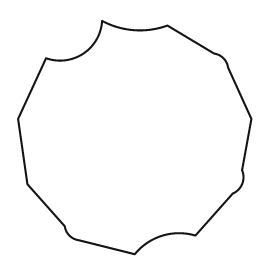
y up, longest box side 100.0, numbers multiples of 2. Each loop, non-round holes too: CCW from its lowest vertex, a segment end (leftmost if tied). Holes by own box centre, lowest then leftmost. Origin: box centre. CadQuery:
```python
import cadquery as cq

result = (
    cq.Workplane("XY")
    .moveTo(0.0, -50.0)
    .threePointArc((12.0, -42.0), (26.0, -42.0))
    .lineTo(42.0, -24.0)
    .threePointArc((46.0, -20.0), (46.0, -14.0))
    .lineTo(50.0, 8.0)
    .lineTo(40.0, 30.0)
    .threePointArc((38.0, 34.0), (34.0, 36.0))
    .lineTo(14.0, 48.0)
    .threePointArc((0.0, 46.0), (-14.0, 50.0))
    .threePointArc((-22.0, 36.0), (-38.0, 34.0))
    .lineTo(-50.0, 8.0)
    .lineTo(-46.0, -20.0)
    .lineTo(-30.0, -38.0)
    .threePointArc((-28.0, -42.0), (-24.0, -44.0))
    .close()
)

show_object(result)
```